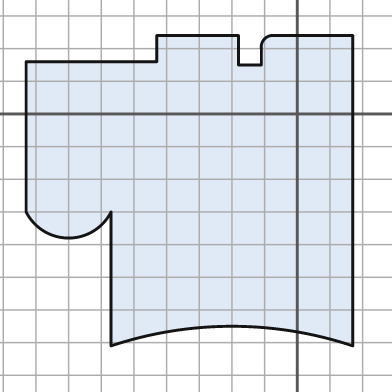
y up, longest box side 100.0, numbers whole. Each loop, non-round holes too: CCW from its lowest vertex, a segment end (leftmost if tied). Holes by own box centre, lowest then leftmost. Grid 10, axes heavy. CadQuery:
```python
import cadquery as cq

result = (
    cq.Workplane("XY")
    .moveTo(-57.0, -71.0)
    .threePointArc((-20.0, -65.0), (17.0, -71.0))
    .lineTo(17.0, 24.0)
    .lineTo(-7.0, 24.0)
    .threePointArc((-10.0, 23.0), (-11.0, 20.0))
    .lineTo(-11.0, 15.0)
    .lineTo(-18.0, 15.0)
    .lineTo(-18.0, 24.0)
    .lineTo(-43.0, 24.0)
    .lineTo(-43.0, 16.0)
    .lineTo(-83.0, 16.0)
    .lineTo(-83.0, -30.0)
    .threePointArc((-70.0, -38.0), (-57.0, -30.0))
    .close()
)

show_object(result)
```